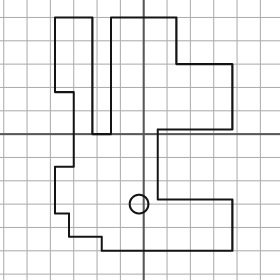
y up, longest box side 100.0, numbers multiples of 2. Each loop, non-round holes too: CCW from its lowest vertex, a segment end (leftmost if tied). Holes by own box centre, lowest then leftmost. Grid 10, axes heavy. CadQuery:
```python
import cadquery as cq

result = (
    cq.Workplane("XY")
    .moveTo(-18.0, -50.0)
    .lineTo(38.0, -50.0)
    .lineTo(38.0, -28.0)
    .lineTo(6.0, -28.0)
    .lineTo(6.0, 2.0)
    .lineTo(38.0, 2.0)
    .lineTo(38.0, 30.0)
    .lineTo(14.0, 30.0)
    .lineTo(14.0, 50.0)
    .lineTo(-14.0, 50.0)
    .lineTo(-14.0, 0.0)
    .lineTo(-22.0, 0.0)
    .lineTo(-22.0, 50.0)
    .lineTo(-38.0, 50.0)
    .lineTo(-38.0, 18.0)
    .lineTo(-30.0, 18.0)
    .lineTo(-30.0, -14.0)
    .lineTo(-38.0, -14.0)
    .lineTo(-38.0, -34.0)
    .lineTo(-32.0, -34.0)
    .lineTo(-32.0, -44.0)
    .lineTo(-18.0, -44.0)
    .close()
    .moveTo(-2.0, -30.0)
    .circle(4.0)
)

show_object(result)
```